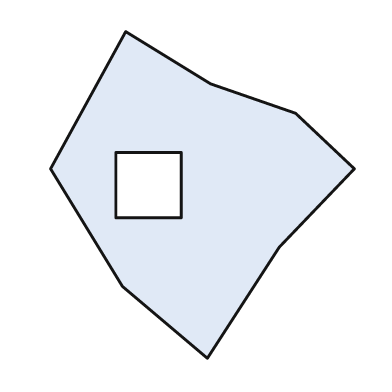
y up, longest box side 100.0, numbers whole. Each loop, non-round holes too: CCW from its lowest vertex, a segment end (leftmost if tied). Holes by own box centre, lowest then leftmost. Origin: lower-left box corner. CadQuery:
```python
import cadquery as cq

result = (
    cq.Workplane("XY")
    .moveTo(48.0, 0.0)
    .lineTo(70.0, 34.0)
    .lineTo(93.0, 58.0)
    .lineTo(75.0, 75.0)
    .lineTo(49.0, 84.0)
    .lineTo(23.0, 100.0)
    .lineTo(0.0, 58.0)
    .lineTo(22.0, 22.0)
    .close()
    .moveTo(20.0, 43.0)
    .lineTo(40.0, 43.0)
    .lineTo(40.0, 63.0)
    .lineTo(20.0, 63.0)
    .close()
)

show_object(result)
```